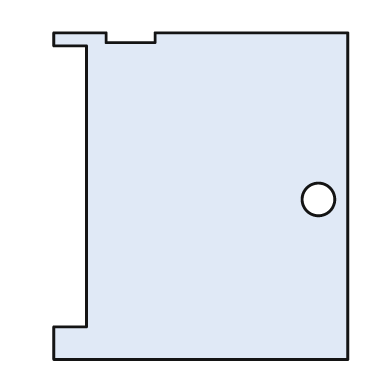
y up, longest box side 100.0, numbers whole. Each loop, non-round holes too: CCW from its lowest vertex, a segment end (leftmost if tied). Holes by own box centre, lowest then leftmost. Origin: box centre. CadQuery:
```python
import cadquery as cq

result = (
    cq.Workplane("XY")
    .moveTo(-45.0, -50.0)
    .lineTo(45.0, -50.0)
    .lineTo(45.0, 50.0)
    .lineTo(-14.0, 50.0)
    .lineTo(-14.0, 47.0)
    .lineTo(-29.0, 47.0)
    .lineTo(-29.0, 50.0)
    .lineTo(-45.0, 50.0)
    .lineTo(-45.0, 46.0)
    .lineTo(-35.0, 46.0)
    .lineTo(-35.0, -40.0)
    .lineTo(-45.0, -40.0)
    .close()
    .moveTo(36.0, -1.0)
    .circle(5.0)
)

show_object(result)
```